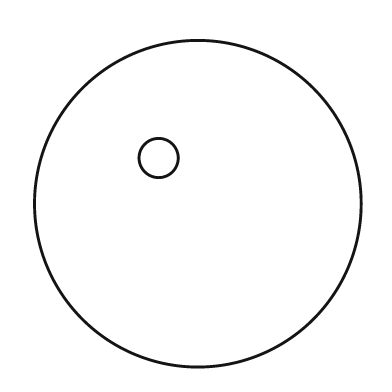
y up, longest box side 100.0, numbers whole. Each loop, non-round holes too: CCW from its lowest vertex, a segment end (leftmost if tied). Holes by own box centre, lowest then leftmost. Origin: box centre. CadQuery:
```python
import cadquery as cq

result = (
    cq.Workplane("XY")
    .moveTo(0.0, 0.0)
    .circle(50.0)
    .moveTo(-12.0, 14.0)
    .circle(6.0)
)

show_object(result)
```